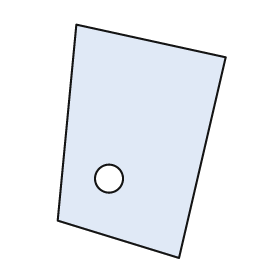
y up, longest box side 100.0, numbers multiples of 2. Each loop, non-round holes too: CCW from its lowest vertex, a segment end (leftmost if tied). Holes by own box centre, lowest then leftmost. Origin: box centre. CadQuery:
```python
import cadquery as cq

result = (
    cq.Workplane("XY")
    .moveTo(16.0, -50.0)
    .lineTo(36.0, 36.0)
    .lineTo(-28.0, 50.0)
    .lineTo(-36.0, -34.0)
    .close()
    .moveTo(-14.0, -16.0)
    .circle(6.0)
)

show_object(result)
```